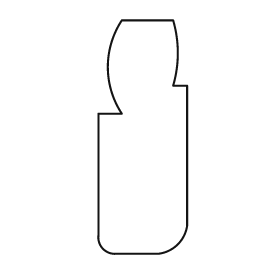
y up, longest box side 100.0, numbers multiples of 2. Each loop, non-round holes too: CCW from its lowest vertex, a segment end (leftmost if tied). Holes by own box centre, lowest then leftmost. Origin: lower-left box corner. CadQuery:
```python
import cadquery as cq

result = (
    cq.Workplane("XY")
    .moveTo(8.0, 0.0)
    .lineTo(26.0, 0.0)
    .threePointArc((34.0, 4.0), (38.0, 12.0))
    .lineTo(38.0, 72.0)
    .lineTo(32.0, 72.0)
    .threePointArc((34.0, 86.0), (32.0, 100.0))
    .lineTo(10.0, 100.0)
    .threePointArc((4.0, 80.0), (10.0, 60.0))
    .lineTo(0.0, 60.0)
    .lineTo(0.0, 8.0)
    .threePointArc((2.0, 2.0), (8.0, 0.0))
    .close()
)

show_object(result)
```